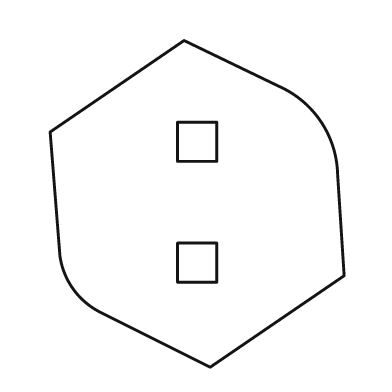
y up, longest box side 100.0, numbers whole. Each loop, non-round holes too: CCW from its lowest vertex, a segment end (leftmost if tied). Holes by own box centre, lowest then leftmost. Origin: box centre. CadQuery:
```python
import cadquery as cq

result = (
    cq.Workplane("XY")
    .moveTo(4.0, -50.0)
    .lineTo(45.0, -22.0)
    .lineTo(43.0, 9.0)
    .threePointArc((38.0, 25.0), (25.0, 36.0))
    .lineTo(-4.0, 50.0)
    .lineTo(-45.0, 22.0)
    .lineTo(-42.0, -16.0)
    .threePointArc((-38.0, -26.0), (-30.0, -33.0))
    .close()
    .moveTo(-6.0, -24.0)
    .lineTo(6.0, -24.0)
    .lineTo(6.0, -12.0)
    .lineTo(-6.0, -12.0)
    .close()
    .moveTo(-6.0, 13.0)
    .lineTo(6.0, 13.0)
    .lineTo(6.0, 25.0)
    .lineTo(-6.0, 25.0)
    .close()
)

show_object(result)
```